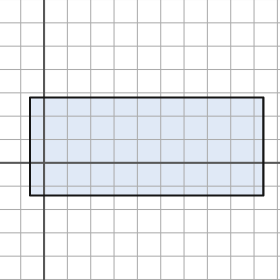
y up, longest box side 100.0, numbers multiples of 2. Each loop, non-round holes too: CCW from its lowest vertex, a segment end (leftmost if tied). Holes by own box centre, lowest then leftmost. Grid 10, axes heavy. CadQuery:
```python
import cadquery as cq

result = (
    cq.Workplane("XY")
    .moveTo(-6.0, -14.0)
    .lineTo(94.0, -14.0)
    .lineTo(94.0, 28.0)
    .lineTo(-6.0, 28.0)
    .close()
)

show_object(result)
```